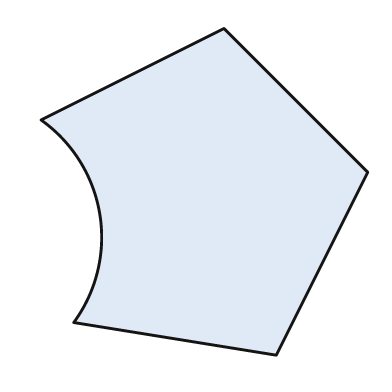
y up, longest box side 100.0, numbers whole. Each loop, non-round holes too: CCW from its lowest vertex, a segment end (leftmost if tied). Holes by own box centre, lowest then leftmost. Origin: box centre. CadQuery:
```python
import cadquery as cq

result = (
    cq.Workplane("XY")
    .moveTo(22.0, -50.0)
    .lineTo(50.0, 6.0)
    .lineTo(6.0, 50.0)
    .lineTo(-50.0, 22.0)
    .threePointArc((-32.0, -7.0), (-40.0, -40.0))
    .close()
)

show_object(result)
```